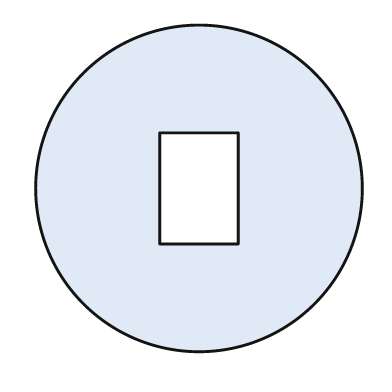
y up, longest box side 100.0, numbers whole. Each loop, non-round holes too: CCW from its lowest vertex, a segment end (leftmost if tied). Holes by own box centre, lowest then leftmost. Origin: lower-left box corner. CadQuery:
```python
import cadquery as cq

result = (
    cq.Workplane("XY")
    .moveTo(50.0, 50.0)
    .circle(50.0)
    .moveTo(38.0, 33.0)
    .lineTo(62.0, 33.0)
    .lineTo(62.0, 67.0)
    .lineTo(38.0, 67.0)
    .close()
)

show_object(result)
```